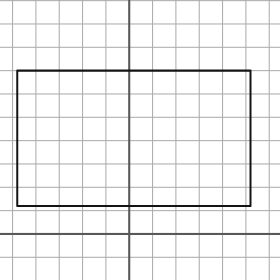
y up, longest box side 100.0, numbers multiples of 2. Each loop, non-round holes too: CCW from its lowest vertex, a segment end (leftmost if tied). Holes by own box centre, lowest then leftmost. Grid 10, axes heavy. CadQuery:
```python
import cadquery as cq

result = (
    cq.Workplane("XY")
    .moveTo(-48.0, 12.0)
    .lineTo(52.0, 12.0)
    .lineTo(52.0, 70.0)
    .lineTo(-48.0, 70.0)
    .close()
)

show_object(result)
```